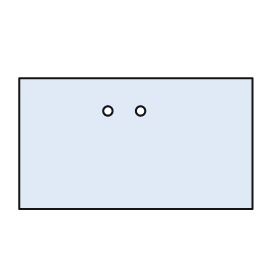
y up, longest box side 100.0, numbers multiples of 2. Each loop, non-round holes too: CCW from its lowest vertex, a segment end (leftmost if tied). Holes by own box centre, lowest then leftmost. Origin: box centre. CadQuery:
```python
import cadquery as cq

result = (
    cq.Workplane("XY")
    .moveTo(-50.0, -28.0)
    .lineTo(50.0, -28.0)
    .lineTo(50.0, 28.0)
    .lineTo(-50.0, 28.0)
    .close()
    .moveTo(-12.0, 14.0)
    .circle(2.0)
    .moveTo(2.0, 14.0)
    .circle(2.0)
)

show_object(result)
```